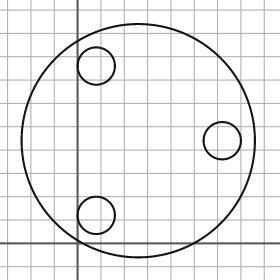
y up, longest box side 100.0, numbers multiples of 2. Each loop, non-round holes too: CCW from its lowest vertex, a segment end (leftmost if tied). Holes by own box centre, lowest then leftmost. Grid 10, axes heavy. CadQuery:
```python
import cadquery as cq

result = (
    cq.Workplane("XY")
    .moveTo(26.0, 44.0)
    .circle(50.0)
    .moveTo(8.0, 12.0)
    .circle(8.0)
    .moveTo(62.0, 44.0)
    .circle(8.0)
    .moveTo(8.0, 76.0)
    .circle(8.0)
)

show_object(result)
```